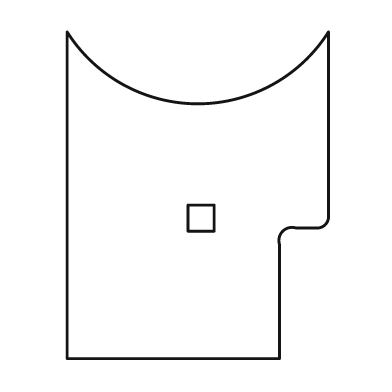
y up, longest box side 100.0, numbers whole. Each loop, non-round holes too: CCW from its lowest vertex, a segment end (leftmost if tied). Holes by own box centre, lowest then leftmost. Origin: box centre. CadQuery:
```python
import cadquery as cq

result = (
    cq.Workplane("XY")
    .moveTo(-40.0, -50.0)
    .lineTo(25.0, -50.0)
    .lineTo(25.0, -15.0)
    .threePointArc((26.0, -11.0), (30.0, -10.0))
    .lineTo(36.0, -10.0)
    .threePointArc((39.0, -9.0), (40.0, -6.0))
    .lineTo(40.0, 50.0)
    .threePointArc((0.0, 28.0), (-40.0, 50.0))
    .close()
    .moveTo(-3.0, -11.0)
    .lineTo(5.0, -11.0)
    .lineTo(5.0, -3.0)
    .lineTo(-3.0, -3.0)
    .close()
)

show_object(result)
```